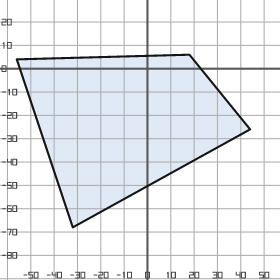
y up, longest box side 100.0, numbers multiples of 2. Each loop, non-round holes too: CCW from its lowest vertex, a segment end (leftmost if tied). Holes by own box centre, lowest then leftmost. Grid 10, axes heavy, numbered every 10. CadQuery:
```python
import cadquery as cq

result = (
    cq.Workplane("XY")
    .moveTo(-32.0, -68.0)
    .lineTo(44.0, -26.0)
    .lineTo(18.0, 6.0)
    .lineTo(-56.0, 4.0)
    .close()
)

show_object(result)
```